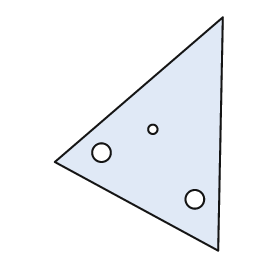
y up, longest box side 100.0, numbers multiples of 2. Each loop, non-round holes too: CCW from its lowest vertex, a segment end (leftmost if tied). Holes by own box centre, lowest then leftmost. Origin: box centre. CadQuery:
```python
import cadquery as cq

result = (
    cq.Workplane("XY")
    .moveTo(34.0, -50.0)
    .lineTo(36.0, 50.0)
    .lineTo(-36.0, -12.0)
    .close()
    .moveTo(24.0, -28.0)
    .circle(4.0)
    .moveTo(-16.0, -8.0)
    .circle(4.0)
    .moveTo(6.0, 2.0)
    .circle(2.0)
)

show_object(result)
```